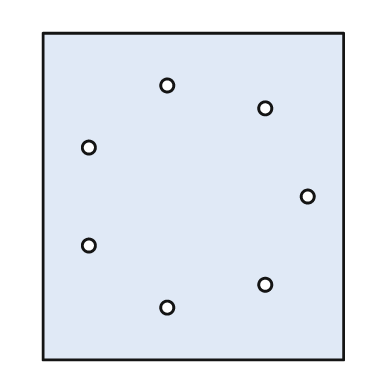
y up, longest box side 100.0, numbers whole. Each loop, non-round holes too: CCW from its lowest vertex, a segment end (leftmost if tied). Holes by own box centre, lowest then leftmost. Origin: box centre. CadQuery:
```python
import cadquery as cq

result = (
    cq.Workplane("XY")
    .moveTo(-46.0, -50.0)
    .lineTo(46.0, -50.0)
    .lineTo(46.0, 50.0)
    .lineTo(-46.0, 50.0)
    .close()
    .moveTo(-8.0, -34.0)
    .circle(2.0)
    .moveTo(22.0, -27.0)
    .circle(2.0)
    .moveTo(-32.0, -15.0)
    .circle(2.0)
    .moveTo(35.0, 0.0)
    .circle(2.0)
    .moveTo(-32.0, 15.0)
    .circle(2.0)
    .moveTo(22.0, 27.0)
    .circle(2.0)
    .moveTo(-8.0, 34.0)
    .circle(2.0)
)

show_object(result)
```